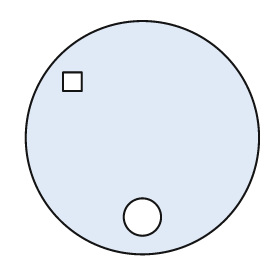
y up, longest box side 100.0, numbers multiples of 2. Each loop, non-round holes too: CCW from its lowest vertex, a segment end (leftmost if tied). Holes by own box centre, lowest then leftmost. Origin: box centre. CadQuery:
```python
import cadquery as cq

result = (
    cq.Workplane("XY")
    .moveTo(0.0, 0.0)
    .circle(50.0)
    .moveTo(0.0, -34.0)
    .circle(8.0)
    .moveTo(-34.0, 20.0)
    .lineTo(-26.0, 20.0)
    .lineTo(-26.0, 28.0)
    .lineTo(-34.0, 28.0)
    .close()
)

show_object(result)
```